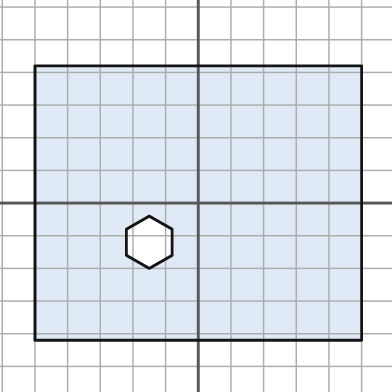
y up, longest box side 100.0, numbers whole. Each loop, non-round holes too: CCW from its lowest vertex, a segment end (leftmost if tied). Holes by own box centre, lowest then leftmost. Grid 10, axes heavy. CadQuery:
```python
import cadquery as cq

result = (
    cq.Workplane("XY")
    .moveTo(-50.0, -42.0)
    .lineTo(50.0, -42.0)
    .lineTo(50.0, 42.0)
    .lineTo(-50.0, 42.0)
    .close()
    .moveTo(-15.0, -20.0)
    .lineTo(-8.0, -16.0)
    .lineTo(-8.0, -8.0)
    .lineTo(-15.0, -4.0)
    .lineTo(-22.0, -8.0)
    .lineTo(-22.0, -16.0)
    .close()
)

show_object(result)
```